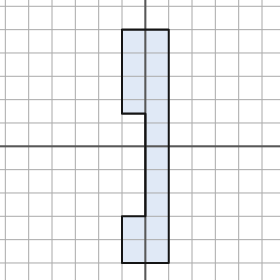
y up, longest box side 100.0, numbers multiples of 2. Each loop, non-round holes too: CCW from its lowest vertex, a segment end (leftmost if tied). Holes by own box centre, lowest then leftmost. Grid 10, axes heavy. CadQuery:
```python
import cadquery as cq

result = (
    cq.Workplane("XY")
    .moveTo(-10.0, -50.0)
    .lineTo(10.0, -50.0)
    .lineTo(10.0, 50.0)
    .lineTo(-10.0, 50.0)
    .lineTo(-10.0, 14.0)
    .lineTo(0.0, 14.0)
    .lineTo(0.0, -30.0)
    .lineTo(-10.0, -30.0)
    .close()
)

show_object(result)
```